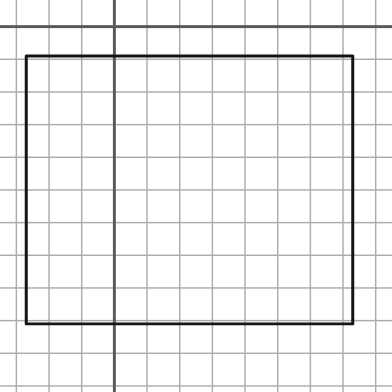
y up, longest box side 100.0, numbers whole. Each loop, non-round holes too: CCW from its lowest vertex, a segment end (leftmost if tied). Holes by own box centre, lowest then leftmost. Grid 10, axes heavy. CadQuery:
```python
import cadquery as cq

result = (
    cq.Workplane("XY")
    .moveTo(-27.0, -91.0)
    .lineTo(73.0, -91.0)
    .lineTo(73.0, -9.0)
    .lineTo(-27.0, -9.0)
    .close()
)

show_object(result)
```